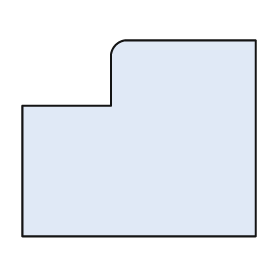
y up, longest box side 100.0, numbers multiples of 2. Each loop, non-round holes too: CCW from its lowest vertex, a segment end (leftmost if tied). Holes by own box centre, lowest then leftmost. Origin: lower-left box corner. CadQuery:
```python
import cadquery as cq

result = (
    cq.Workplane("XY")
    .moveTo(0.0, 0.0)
    .lineTo(100.0, 0.0)
    .lineTo(100.0, 84.0)
    .lineTo(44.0, 84.0)
    .threePointArc((40.0, 82.0), (38.0, 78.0))
    .lineTo(38.0, 56.0)
    .lineTo(0.0, 56.0)
    .close()
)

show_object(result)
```